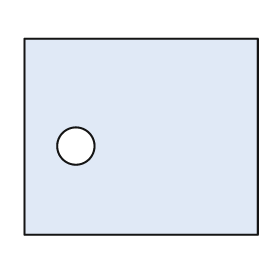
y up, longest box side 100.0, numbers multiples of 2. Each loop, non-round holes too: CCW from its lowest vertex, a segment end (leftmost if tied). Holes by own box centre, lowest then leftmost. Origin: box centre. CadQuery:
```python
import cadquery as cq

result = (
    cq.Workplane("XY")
    .moveTo(-50.0, -42.0)
    .lineTo(50.0, -42.0)
    .lineTo(50.0, 42.0)
    .lineTo(-50.0, 42.0)
    .close()
    .moveTo(-28.0, -4.0)
    .circle(8.0)
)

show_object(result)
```